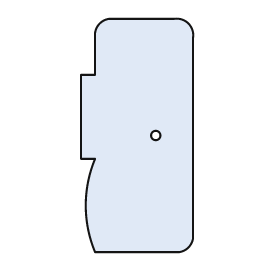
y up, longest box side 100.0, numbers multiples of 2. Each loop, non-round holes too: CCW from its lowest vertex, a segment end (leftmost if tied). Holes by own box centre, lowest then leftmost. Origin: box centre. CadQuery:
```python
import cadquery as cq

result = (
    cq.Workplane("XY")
    .moveTo(-18.0, -50.0)
    .lineTo(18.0, -50.0)
    .threePointArc((22.0, -48.0), (24.0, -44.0))
    .lineTo(24.0, 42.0)
    .threePointArc((22.0, 48.0), (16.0, 50.0))
    .lineTo(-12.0, 50.0)
    .threePointArc((-16.0, 48.0), (-18.0, 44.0))
    .lineTo(-18.0, 26.0)
    .lineTo(-24.0, 26.0)
    .lineTo(-24.0, -10.0)
    .lineTo(-18.0, -10.0)
    .threePointArc((-22.0, -30.0), (-18.0, -50.0))
    .close()
    .moveTo(8.0, 0.0)
    .circle(2.0)
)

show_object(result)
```